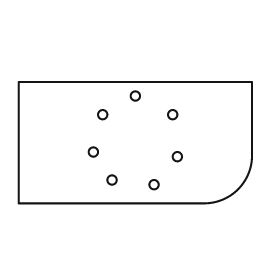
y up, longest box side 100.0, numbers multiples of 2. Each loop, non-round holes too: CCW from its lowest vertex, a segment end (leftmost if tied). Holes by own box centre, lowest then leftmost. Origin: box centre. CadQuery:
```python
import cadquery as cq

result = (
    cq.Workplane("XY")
    .moveTo(-50.0, -26.0)
    .lineTo(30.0, -26.0)
    .threePointArc((44.0, -20.0), (50.0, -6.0))
    .lineTo(50.0, 26.0)
    .lineTo(-50.0, 26.0)
    .close()
    .moveTo(8.0, -18.0)
    .circle(2.0)
    .moveTo(-10.0, -16.0)
    .circle(2.0)
    .moveTo(18.0, -6.0)
    .circle(2.0)
    .moveTo(-18.0, -4.0)
    .circle(2.0)
    .moveTo(-14.0, 12.0)
    .circle(2.0)
    .moveTo(16.0, 12.0)
    .circle(2.0)
    .moveTo(0.0, 20.0)
    .circle(2.0)
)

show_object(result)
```